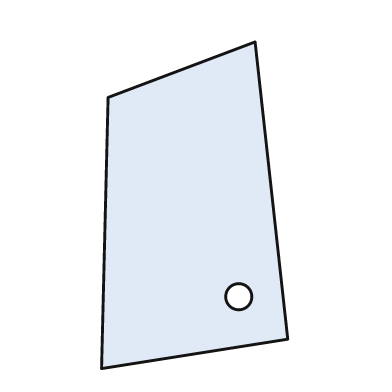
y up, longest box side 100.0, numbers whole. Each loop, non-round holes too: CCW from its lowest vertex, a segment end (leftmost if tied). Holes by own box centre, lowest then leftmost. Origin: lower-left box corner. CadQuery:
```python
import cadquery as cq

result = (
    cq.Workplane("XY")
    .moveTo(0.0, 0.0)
    .lineTo(57.0, 9.0)
    .lineTo(47.0, 100.0)
    .lineTo(2.0, 83.0)
    .close()
    .moveTo(42.0, 22.0)
    .circle(4.0)
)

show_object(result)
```